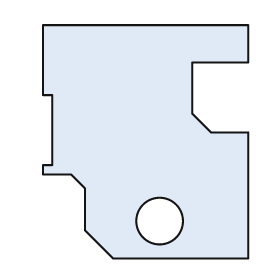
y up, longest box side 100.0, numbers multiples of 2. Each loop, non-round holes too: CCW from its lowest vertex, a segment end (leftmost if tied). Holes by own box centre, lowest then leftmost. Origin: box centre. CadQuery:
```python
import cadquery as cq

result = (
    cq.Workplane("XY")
    .moveTo(-14.0, -50.0)
    .lineTo(44.0, -50.0)
    .lineTo(44.0, 4.0)
    .lineTo(28.0, 4.0)
    .lineTo(20.0, 12.0)
    .lineTo(20.0, 34.0)
    .lineTo(44.0, 34.0)
    .lineTo(44.0, 50.0)
    .lineTo(-44.0, 50.0)
    .lineTo(-44.0, 20.0)
    .lineTo(-40.0, 20.0)
    .lineTo(-40.0, -10.0)
    .lineTo(-44.0, -10.0)
    .lineTo(-44.0, -14.0)
    .lineTo(-32.0, -14.0)
    .lineTo(-26.0, -20.0)
    .lineTo(-26.0, -38.0)
    .close()
    .moveTo(6.0, -34.0)
    .circle(10.0)
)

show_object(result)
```